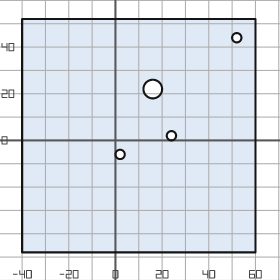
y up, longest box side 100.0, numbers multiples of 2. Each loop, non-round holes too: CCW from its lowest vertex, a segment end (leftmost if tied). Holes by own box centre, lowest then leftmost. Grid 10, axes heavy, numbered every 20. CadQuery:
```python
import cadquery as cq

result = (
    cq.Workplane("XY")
    .moveTo(-40.0, -48.0)
    .lineTo(60.0, -48.0)
    .lineTo(60.0, 52.0)
    .lineTo(-40.0, 52.0)
    .close()
    .moveTo(2.0, -6.0)
    .circle(2.0)
    .moveTo(24.0, 2.0)
    .circle(2.0)
    .moveTo(16.0, 22.0)
    .circle(4.0)
    .moveTo(52.0, 44.0)
    .circle(2.0)
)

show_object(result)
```